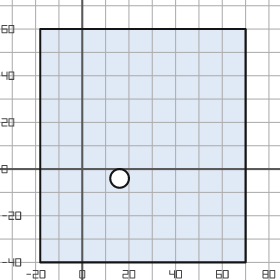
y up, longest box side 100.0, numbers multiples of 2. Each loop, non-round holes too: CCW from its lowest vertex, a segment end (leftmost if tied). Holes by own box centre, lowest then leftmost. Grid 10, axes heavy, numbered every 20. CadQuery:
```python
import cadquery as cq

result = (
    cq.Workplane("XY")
    .moveTo(-18.0, -40.0)
    .lineTo(70.0, -40.0)
    .lineTo(70.0, 60.0)
    .lineTo(-18.0, 60.0)
    .close()
    .moveTo(16.0, -4.0)
    .circle(4.0)
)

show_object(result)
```